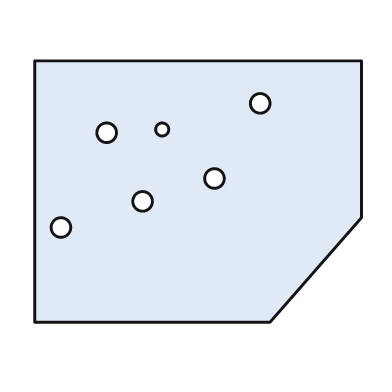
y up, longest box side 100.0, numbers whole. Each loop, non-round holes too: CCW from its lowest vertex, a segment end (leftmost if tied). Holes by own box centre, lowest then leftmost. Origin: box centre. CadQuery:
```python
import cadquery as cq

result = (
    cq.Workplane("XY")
    .moveTo(-50.0, -40.0)
    .lineTo(22.0, -40.0)
    .lineTo(50.0, -8.0)
    .lineTo(50.0, 40.0)
    .lineTo(-50.0, 40.0)
    .close()
    .moveTo(-42.0, -11.0)
    .circle(3.0)
    .moveTo(-17.0, -3.0)
    .circle(3.0)
    .moveTo(5.0, 4.0)
    .circle(3.0)
    .moveTo(-28.0, 18.0)
    .circle(3.0)
    .moveTo(-11.0, 19.0)
    .circle(2.0)
    .moveTo(19.0, 27.0)
    .circle(3.0)
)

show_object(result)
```